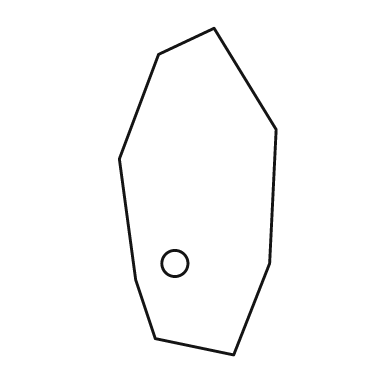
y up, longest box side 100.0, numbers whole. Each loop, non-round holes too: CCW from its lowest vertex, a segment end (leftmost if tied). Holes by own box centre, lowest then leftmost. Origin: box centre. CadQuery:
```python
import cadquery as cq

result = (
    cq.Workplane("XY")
    .moveTo(11.0, -50.0)
    .lineTo(22.0, -22.0)
    .lineTo(24.0, 19.0)
    .lineTo(5.0, 50.0)
    .lineTo(-12.0, 42.0)
    .lineTo(-24.0, 10.0)
    .lineTo(-19.0, -27.0)
    .lineTo(-13.0, -45.0)
    .close()
    .moveTo(-7.0, -22.0)
    .circle(4.0)
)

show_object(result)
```